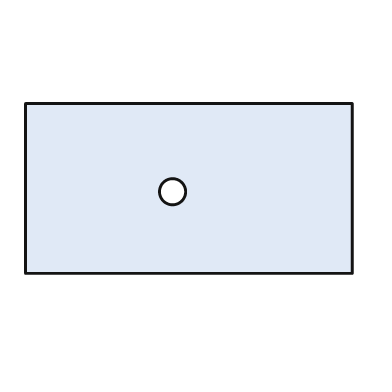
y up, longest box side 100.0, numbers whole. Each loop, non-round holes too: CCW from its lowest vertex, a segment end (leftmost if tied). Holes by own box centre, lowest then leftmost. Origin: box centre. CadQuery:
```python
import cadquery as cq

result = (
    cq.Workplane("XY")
    .moveTo(-50.0, -26.0)
    .lineTo(50.0, -26.0)
    .lineTo(50.0, 26.0)
    .lineTo(-50.0, 26.0)
    .close()
    .moveTo(-5.0, -1.0)
    .circle(4.0)
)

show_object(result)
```